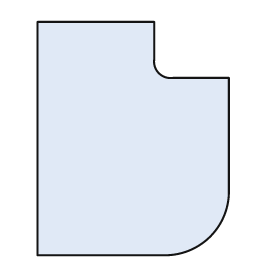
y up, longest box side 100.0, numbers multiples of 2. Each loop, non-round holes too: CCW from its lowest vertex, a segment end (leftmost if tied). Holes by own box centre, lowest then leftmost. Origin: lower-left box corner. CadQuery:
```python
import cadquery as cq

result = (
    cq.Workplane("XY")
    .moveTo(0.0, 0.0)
    .lineTo(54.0, 0.0)
    .threePointArc((74.0, 8.0), (82.0, 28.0))
    .lineTo(82.0, 76.0)
    .lineTo(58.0, 76.0)
    .threePointArc((52.0, 78.0), (50.0, 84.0))
    .lineTo(50.0, 100.0)
    .lineTo(0.0, 100.0)
    .close()
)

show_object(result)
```